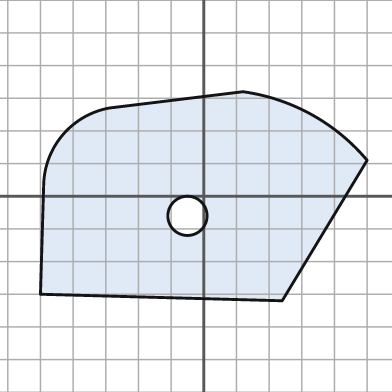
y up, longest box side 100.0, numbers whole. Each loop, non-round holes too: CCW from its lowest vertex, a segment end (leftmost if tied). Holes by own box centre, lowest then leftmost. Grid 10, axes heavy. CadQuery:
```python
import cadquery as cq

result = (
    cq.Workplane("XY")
    .moveTo(24.0, -32.0)
    .lineTo(50.0, 11.0)
    .threePointArc((33.0, 25.0), (12.0, 32.0))
    .lineTo(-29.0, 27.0)
    .threePointArc((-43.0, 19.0), (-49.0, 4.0))
    .lineTo(-50.0, -30.0)
    .close()
    .moveTo(-5.0, -6.0)
    .circle(6.0)
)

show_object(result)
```